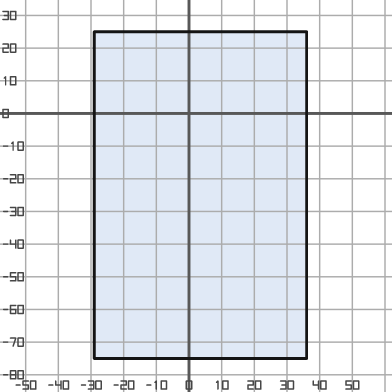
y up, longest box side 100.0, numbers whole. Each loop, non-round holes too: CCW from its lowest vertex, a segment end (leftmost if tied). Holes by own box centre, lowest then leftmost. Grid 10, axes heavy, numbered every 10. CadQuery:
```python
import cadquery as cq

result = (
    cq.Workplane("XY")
    .moveTo(-29.0, -75.0)
    .lineTo(36.0, -75.0)
    .lineTo(36.0, 25.0)
    .lineTo(-29.0, 25.0)
    .close()
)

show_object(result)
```